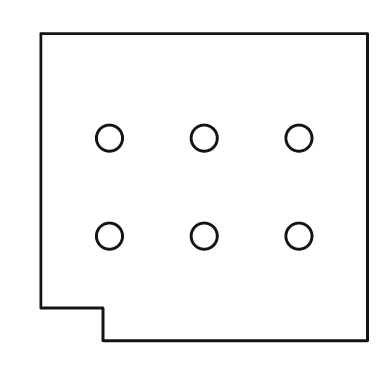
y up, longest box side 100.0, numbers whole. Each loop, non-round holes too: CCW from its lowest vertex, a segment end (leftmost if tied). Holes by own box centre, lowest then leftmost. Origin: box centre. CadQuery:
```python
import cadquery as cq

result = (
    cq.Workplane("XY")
    .moveTo(-31.0, -47.0)
    .lineTo(50.0, -47.0)
    .lineTo(50.0, 47.0)
    .lineTo(-50.0, 47.0)
    .lineTo(-50.0, -37.0)
    .lineTo(-31.0, -37.0)
    .close()
    .moveTo(-29.0, -15.0)
    .circle(4.0)
    .moveTo(0.0, -15.0)
    .circle(4.0)
    .moveTo(29.0, -15.0)
    .circle(4.0)
    .moveTo(-29.0, 15.0)
    .circle(4.0)
    .moveTo(0.0, 15.0)
    .circle(4.0)
    .moveTo(29.0, 15.0)
    .circle(4.0)
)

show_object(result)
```